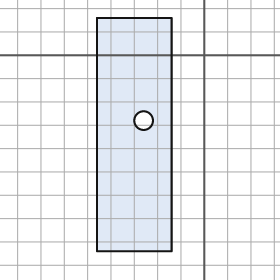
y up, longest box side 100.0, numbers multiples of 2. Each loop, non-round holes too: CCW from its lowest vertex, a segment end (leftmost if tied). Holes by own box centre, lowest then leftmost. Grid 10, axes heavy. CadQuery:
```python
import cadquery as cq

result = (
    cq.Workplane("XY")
    .moveTo(-46.0, -84.0)
    .lineTo(-14.0, -84.0)
    .lineTo(-14.0, 16.0)
    .lineTo(-46.0, 16.0)
    .close()
    .moveTo(-26.0, -28.0)
    .circle(4.0)
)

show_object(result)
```